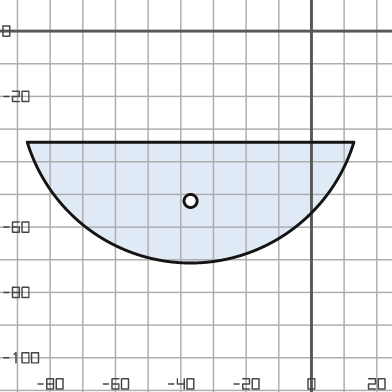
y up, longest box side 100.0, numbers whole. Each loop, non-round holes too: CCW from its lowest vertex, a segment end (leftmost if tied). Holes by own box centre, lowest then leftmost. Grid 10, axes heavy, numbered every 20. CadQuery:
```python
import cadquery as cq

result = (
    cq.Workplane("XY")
    .moveTo(-87.0, -34.0)
    .threePointArc((-37.0, -71.0), (13.0, -34.0))
    .close()
    .moveTo(-37.0, -52.0)
    .circle(2.0)
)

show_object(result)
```